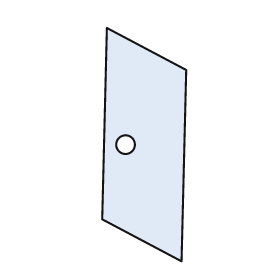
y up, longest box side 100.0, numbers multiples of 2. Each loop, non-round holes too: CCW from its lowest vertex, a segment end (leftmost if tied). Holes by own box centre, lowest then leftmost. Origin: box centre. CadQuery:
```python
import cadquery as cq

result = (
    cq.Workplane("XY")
    .moveTo(16.0, -50.0)
    .lineTo(18.0, 32.0)
    .lineTo(-16.0, 50.0)
    .lineTo(-18.0, -32.0)
    .close()
    .moveTo(-8.0, 0.0)
    .circle(4.0)
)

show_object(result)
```